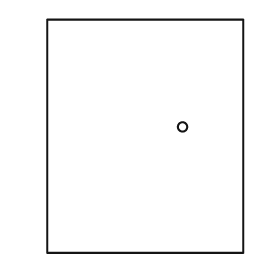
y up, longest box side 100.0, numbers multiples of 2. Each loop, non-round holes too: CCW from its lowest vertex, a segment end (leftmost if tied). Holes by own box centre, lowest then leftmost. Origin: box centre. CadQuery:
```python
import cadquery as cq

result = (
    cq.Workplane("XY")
    .moveTo(-42.0, -50.0)
    .lineTo(42.0, -50.0)
    .lineTo(42.0, 50.0)
    .lineTo(-42.0, 50.0)
    .close()
    .moveTo(16.0, 4.0)
    .circle(2.0)
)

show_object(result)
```